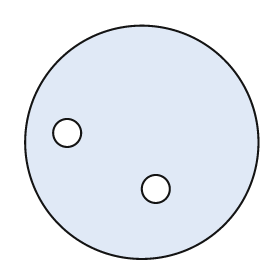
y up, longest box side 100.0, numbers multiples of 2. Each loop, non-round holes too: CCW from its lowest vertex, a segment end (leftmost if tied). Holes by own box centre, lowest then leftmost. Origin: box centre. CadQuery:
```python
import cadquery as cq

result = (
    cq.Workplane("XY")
    .moveTo(0.0, 0.0)
    .circle(50.0)
    .moveTo(6.0, -20.0)
    .circle(6.0)
    .moveTo(-32.0, 4.0)
    .circle(6.0)
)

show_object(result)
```